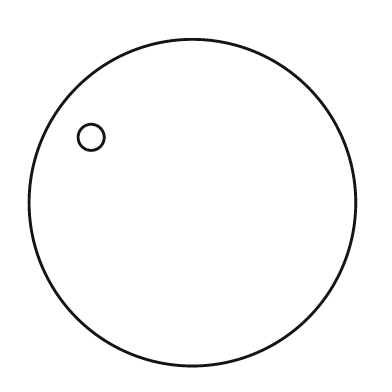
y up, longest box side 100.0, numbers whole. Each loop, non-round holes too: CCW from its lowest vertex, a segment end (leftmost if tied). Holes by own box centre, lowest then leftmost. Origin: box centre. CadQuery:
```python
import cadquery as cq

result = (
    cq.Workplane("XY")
    .moveTo(0.0, 0.0)
    .circle(50.0)
    .moveTo(-31.0, 20.0)
    .circle(4.0)
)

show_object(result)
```